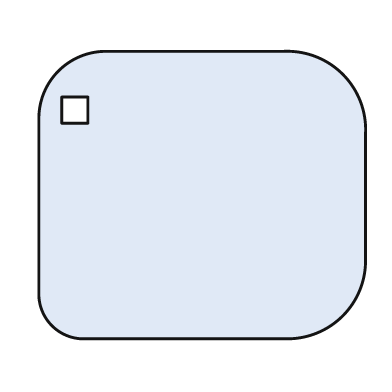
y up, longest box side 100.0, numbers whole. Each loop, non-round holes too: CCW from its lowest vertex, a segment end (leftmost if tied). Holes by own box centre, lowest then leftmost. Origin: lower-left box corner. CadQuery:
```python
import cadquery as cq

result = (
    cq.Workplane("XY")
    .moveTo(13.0, 0.0)
    .lineTo(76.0, 0.0)
    .threePointArc((93.0, 7.0), (100.0, 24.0))
    .lineTo(100.0, 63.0)
    .threePointArc((93.0, 81.0), (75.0, 88.0))
    .lineTo(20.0, 88.0)
    .threePointArc((6.0, 82.0), (0.0, 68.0))
    .lineTo(0.0, 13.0)
    .threePointArc((4.0, 4.0), (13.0, 0.0))
    .close()
    .moveTo(7.0, 66.0)
    .lineTo(15.0, 66.0)
    .lineTo(15.0, 74.0)
    .lineTo(7.0, 74.0)
    .close()
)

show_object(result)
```